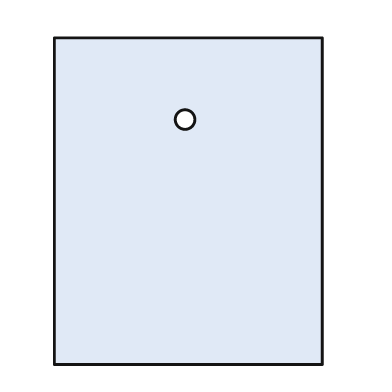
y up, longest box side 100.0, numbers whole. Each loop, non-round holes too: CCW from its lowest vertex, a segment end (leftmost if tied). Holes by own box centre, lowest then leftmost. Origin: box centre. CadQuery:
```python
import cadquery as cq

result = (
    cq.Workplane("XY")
    .moveTo(-41.0, -50.0)
    .lineTo(41.0, -50.0)
    .lineTo(41.0, 50.0)
    .lineTo(-41.0, 50.0)
    .close()
    .moveTo(-1.0, 25.0)
    .circle(3.0)
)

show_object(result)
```